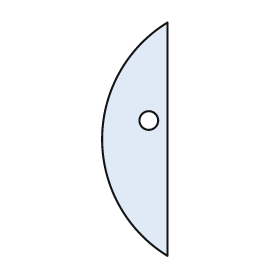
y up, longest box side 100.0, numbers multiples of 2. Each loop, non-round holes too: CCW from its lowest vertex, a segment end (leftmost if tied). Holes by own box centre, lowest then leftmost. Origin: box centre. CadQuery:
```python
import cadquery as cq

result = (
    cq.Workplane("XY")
    .moveTo(14.0, -50.0)
    .lineTo(14.0, 50.0)
    .threePointArc((-14.0, 0.0), (14.0, -50.0))
    .close()
    .moveTo(6.0, 8.0)
    .circle(4.0)
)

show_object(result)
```